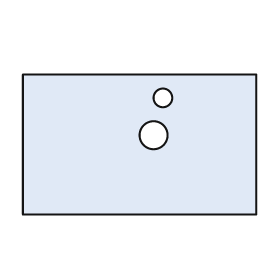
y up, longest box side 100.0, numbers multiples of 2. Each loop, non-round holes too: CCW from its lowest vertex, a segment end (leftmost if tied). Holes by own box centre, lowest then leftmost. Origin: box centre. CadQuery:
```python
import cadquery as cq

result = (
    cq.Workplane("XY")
    .moveTo(-50.0, -30.0)
    .lineTo(50.0, -30.0)
    .lineTo(50.0, 30.0)
    .lineTo(-50.0, 30.0)
    .close()
    .moveTo(6.0, 4.0)
    .circle(6.0)
    .moveTo(10.0, 20.0)
    .circle(4.0)
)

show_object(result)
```